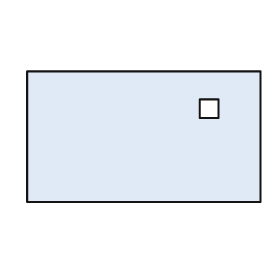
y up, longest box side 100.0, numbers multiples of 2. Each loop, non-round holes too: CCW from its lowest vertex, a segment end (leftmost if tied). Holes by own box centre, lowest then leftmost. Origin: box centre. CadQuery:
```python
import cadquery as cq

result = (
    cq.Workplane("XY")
    .moveTo(-50.0, -28.0)
    .lineTo(50.0, -28.0)
    .lineTo(50.0, 28.0)
    .lineTo(-50.0, 28.0)
    .close()
    .moveTo(24.0, 8.0)
    .lineTo(32.0, 8.0)
    .lineTo(32.0, 16.0)
    .lineTo(24.0, 16.0)
    .close()
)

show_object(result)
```